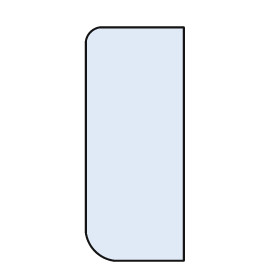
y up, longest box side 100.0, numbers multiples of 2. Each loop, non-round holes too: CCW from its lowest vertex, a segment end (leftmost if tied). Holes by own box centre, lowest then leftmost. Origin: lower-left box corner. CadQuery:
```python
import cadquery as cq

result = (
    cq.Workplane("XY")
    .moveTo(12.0, 0.0)
    .lineTo(42.0, 0.0)
    .lineTo(42.0, 100.0)
    .lineTo(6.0, 100.0)
    .threePointArc((2.0, 98.0), (0.0, 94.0))
    .lineTo(0.0, 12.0)
    .threePointArc((4.0, 4.0), (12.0, 0.0))
    .close()
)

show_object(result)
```